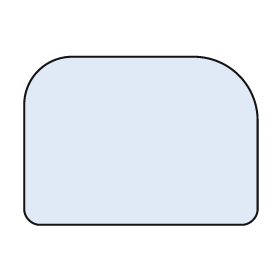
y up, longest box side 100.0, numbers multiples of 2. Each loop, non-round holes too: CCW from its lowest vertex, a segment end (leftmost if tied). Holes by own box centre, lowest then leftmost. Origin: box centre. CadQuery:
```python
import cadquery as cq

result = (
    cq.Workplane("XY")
    .moveTo(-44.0, -36.0)
    .lineTo(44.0, -36.0)
    .threePointArc((48.0, -34.0), (50.0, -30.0))
    .lineTo(50.0, 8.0)
    .threePointArc((42.0, 28.0), (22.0, 36.0))
    .lineTo(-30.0, 36.0)
    .threePointArc((-44.0, 30.0), (-50.0, 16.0))
    .lineTo(-50.0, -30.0)
    .threePointArc((-48.0, -34.0), (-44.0, -36.0))
    .close()
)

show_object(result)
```